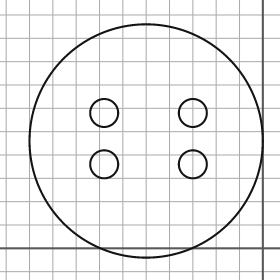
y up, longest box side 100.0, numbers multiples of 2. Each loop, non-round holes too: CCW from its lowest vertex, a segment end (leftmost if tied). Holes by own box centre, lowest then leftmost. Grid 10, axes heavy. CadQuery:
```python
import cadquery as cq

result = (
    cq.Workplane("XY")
    .moveTo(-50.0, 46.0)
    .circle(50.0)
    .moveTo(-68.0, 36.0)
    .circle(6.0)
    .moveTo(-30.0, 36.0)
    .circle(6.0)
    .moveTo(-68.0, 58.0)
    .circle(6.0)
    .moveTo(-30.0, 58.0)
    .circle(6.0)
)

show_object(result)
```